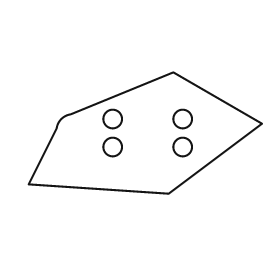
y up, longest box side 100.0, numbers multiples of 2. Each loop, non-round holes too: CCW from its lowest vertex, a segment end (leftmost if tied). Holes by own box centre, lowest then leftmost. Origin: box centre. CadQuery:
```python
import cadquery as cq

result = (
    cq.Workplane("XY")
    .moveTo(10.0, -26.0)
    .lineTo(50.0, 4.0)
    .lineTo(12.0, 26.0)
    .lineTo(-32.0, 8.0)
    .threePointArc((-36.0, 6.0), (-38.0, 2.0))
    .lineTo(-50.0, -22.0)
    .close()
    .moveTo(-14.0, -6.0)
    .circle(4.0)
    .moveTo(16.0, -6.0)
    .circle(4.0)
    .moveTo(-14.0, 6.0)
    .circle(4.0)
    .moveTo(16.0, 6.0)
    .circle(4.0)
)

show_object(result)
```